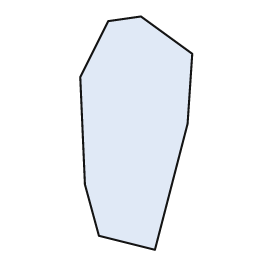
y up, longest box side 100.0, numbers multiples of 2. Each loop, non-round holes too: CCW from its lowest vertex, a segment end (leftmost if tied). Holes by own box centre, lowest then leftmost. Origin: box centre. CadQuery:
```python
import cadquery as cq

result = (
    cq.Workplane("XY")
    .moveTo(8.0, -50.0)
    .lineTo(22.0, 4.0)
    .lineTo(24.0, 34.0)
    .lineTo(2.0, 50.0)
    .lineTo(-12.0, 48.0)
    .lineTo(-24.0, 24.0)
    .lineTo(-22.0, -22.0)
    .lineTo(-16.0, -44.0)
    .close()
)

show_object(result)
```